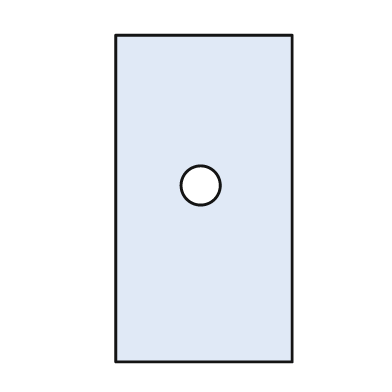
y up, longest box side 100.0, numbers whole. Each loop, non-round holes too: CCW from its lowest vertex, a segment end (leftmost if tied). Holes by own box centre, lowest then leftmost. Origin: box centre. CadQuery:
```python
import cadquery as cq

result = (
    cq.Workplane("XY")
    .moveTo(-27.0, -50.0)
    .lineTo(27.0, -50.0)
    .lineTo(27.0, 50.0)
    .lineTo(-27.0, 50.0)
    .close()
    .moveTo(-1.0, 4.0)
    .circle(6.0)
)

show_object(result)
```